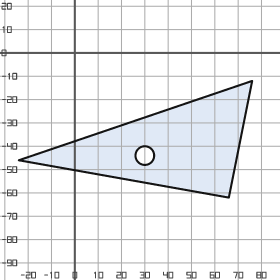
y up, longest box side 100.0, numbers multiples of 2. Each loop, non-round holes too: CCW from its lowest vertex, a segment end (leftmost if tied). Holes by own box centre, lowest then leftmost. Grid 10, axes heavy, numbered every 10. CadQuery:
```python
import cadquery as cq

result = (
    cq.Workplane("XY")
    .moveTo(66.0, -62.0)
    .lineTo(76.0, -12.0)
    .lineTo(-24.0, -46.0)
    .close()
    .moveTo(30.0, -44.0)
    .circle(4.0)
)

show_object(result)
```